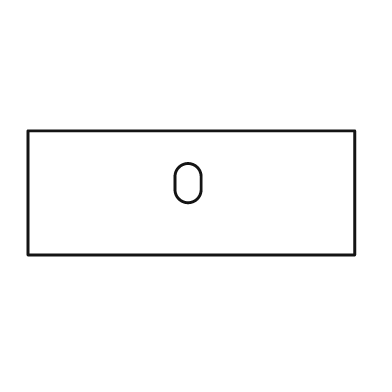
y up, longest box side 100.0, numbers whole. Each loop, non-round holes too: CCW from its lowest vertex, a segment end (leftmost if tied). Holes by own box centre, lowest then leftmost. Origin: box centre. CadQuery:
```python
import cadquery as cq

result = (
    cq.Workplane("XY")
    .moveTo(-50.0, -19.0)
    .lineTo(50.0, -19.0)
    .lineTo(50.0, 19.0)
    .lineTo(-50.0, 19.0)
    .close()
    .moveTo(-5.0, 1.0)
    .threePointArc((-1.0, -3.0), (3.0, 1.0))
    .lineTo(3.0, 5.0)
    .threePointArc((-1.0, 9.0), (-5.0, 5.0))
    .close()
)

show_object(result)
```